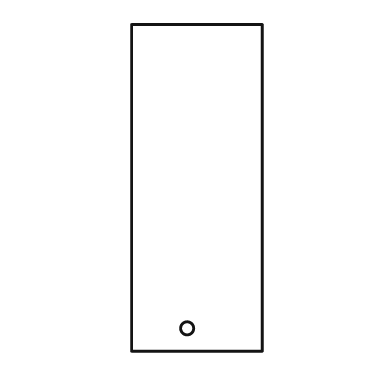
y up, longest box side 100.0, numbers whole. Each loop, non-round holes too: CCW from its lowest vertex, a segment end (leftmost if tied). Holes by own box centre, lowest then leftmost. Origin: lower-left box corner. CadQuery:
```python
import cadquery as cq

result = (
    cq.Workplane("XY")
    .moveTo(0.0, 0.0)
    .lineTo(40.0, 0.0)
    .lineTo(40.0, 100.0)
    .lineTo(0.0, 100.0)
    .close()
    .moveTo(17.0, 7.0)
    .circle(2.0)
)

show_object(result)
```